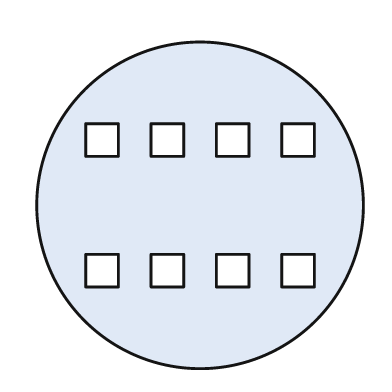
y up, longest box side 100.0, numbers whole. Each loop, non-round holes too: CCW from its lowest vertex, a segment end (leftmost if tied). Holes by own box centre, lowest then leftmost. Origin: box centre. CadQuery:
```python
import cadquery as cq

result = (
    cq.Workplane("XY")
    .moveTo(0.0, 0.0)
    .circle(50.0)
    .moveTo(-35.0, -25.0)
    .lineTo(-25.0, -25.0)
    .lineTo(-25.0, -15.0)
    .lineTo(-35.0, -15.0)
    .close()
    .moveTo(-15.0, -25.0)
    .lineTo(-5.0, -25.0)
    .lineTo(-5.0, -15.0)
    .lineTo(-15.0, -15.0)
    .close()
    .moveTo(5.0, -25.0)
    .lineTo(15.0, -25.0)
    .lineTo(15.0, -15.0)
    .lineTo(5.0, -15.0)
    .close()
    .moveTo(25.0, -25.0)
    .lineTo(35.0, -25.0)
    .lineTo(35.0, -15.0)
    .lineTo(25.0, -15.0)
    .close()
    .moveTo(-35.0, 15.0)
    .lineTo(-25.0, 15.0)
    .lineTo(-25.0, 25.0)
    .lineTo(-35.0, 25.0)
    .close()
    .moveTo(-15.0, 15.0)
    .lineTo(-5.0, 15.0)
    .lineTo(-5.0, 25.0)
    .lineTo(-15.0, 25.0)
    .close()
    .moveTo(5.0, 15.0)
    .lineTo(15.0, 15.0)
    .lineTo(15.0, 25.0)
    .lineTo(5.0, 25.0)
    .close()
    .moveTo(25.0, 15.0)
    .lineTo(35.0, 15.0)
    .lineTo(35.0, 25.0)
    .lineTo(25.0, 25.0)
    .close()
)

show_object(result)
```